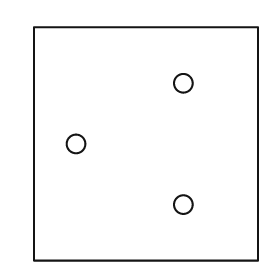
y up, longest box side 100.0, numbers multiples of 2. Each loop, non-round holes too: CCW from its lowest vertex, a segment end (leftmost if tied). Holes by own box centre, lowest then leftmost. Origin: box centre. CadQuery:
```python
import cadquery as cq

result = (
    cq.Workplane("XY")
    .moveTo(-48.0, -50.0)
    .lineTo(48.0, -50.0)
    .lineTo(48.0, 50.0)
    .lineTo(-48.0, 50.0)
    .close()
    .moveTo(16.0, -26.0)
    .circle(4.0)
    .moveTo(-30.0, 0.0)
    .circle(4.0)
    .moveTo(16.0, 26.0)
    .circle(4.0)
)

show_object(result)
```